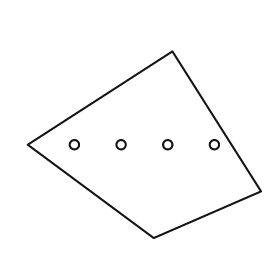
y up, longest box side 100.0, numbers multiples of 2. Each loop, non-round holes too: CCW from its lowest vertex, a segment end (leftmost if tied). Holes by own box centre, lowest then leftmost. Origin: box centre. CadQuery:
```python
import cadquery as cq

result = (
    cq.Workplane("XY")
    .moveTo(4.0, -40.0)
    .lineTo(50.0, -20.0)
    .lineTo(12.0, 40.0)
    .lineTo(-50.0, 0.0)
    .close()
    .moveTo(-30.0, 0.0)
    .circle(2.0)
    .moveTo(-10.0, 0.0)
    .circle(2.0)
    .moveTo(10.0, 0.0)
    .circle(2.0)
    .moveTo(30.0, 0.0)
    .circle(2.0)
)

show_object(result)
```